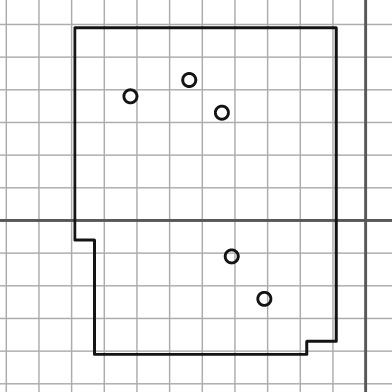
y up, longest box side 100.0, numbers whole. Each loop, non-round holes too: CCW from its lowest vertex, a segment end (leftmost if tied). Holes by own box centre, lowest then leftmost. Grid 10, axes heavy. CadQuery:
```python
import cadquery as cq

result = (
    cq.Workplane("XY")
    .moveTo(-83.0, -41.0)
    .lineTo(-18.0, -41.0)
    .lineTo(-18.0, -37.0)
    .lineTo(-9.0, -37.0)
    .lineTo(-9.0, 59.0)
    .lineTo(-89.0, 59.0)
    .lineTo(-89.0, -6.0)
    .lineTo(-83.0, -6.0)
    .close()
    .moveTo(-31.0, -24.0)
    .circle(2.0)
    .moveTo(-41.0, -11.0)
    .circle(2.0)
    .moveTo(-44.0, 33.0)
    .circle(2.0)
    .moveTo(-72.0, 38.0)
    .circle(2.0)
    .moveTo(-54.0, 43.0)
    .circle(2.0)
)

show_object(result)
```